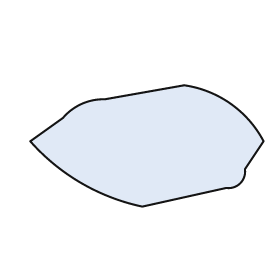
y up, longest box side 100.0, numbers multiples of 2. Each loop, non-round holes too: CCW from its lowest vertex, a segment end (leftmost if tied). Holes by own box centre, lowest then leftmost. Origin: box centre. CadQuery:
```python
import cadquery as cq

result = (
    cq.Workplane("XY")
    .moveTo(-2.0, -26.0)
    .lineTo(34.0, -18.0)
    .threePointArc((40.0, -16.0), (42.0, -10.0))
    .lineTo(50.0, 2.0)
    .threePointArc((36.0, 18.0), (16.0, 26.0))
    .lineTo(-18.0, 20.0)
    .threePointArc((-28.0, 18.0), (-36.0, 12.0))
    .lineTo(-50.0, 2.0)
    .threePointArc((-28.0, -16.0), (-2.0, -26.0))
    .close()
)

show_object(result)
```